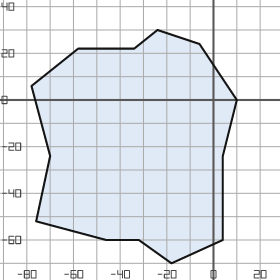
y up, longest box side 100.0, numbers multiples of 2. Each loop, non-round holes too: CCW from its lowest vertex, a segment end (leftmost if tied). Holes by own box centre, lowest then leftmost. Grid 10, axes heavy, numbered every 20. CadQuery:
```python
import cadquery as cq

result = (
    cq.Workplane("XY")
    .moveTo(-18.0, -70.0)
    .lineTo(4.0, -60.0)
    .lineTo(4.0, -24.0)
    .lineTo(10.0, 0.0)
    .lineTo(-6.0, 24.0)
    .lineTo(-24.0, 30.0)
    .lineTo(-34.0, 22.0)
    .lineTo(-58.0, 22.0)
    .lineTo(-78.0, 6.0)
    .lineTo(-70.0, -24.0)
    .lineTo(-76.0, -52.0)
    .lineTo(-46.0, -60.0)
    .lineTo(-32.0, -60.0)
    .close()
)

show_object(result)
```